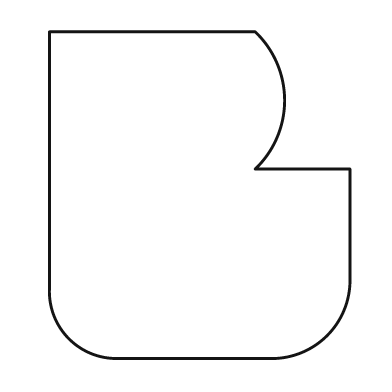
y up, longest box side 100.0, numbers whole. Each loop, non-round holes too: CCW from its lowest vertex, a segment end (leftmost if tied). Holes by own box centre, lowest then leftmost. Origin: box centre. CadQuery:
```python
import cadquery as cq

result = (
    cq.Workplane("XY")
    .moveTo(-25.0, -50.0)
    .lineTo(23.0, -50.0)
    .threePointArc((39.0, -43.0), (46.0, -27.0))
    .lineTo(46.0, 8.0)
    .lineTo(17.0, 8.0)
    .threePointArc((26.0, 29.0), (17.0, 50.0))
    .lineTo(-46.0, 50.0)
    .lineTo(-46.0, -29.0)
    .threePointArc((-40.0, -44.0), (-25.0, -50.0))
    .close()
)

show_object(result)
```